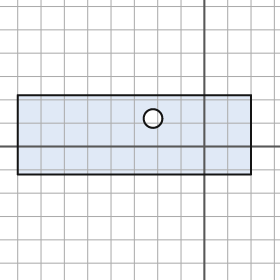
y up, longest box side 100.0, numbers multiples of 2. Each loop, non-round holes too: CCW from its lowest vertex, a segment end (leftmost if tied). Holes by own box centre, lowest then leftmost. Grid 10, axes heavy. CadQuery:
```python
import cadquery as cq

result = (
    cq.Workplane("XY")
    .moveTo(-80.0, -12.0)
    .lineTo(20.0, -12.0)
    .lineTo(20.0, 22.0)
    .lineTo(-80.0, 22.0)
    .close()
    .moveTo(-22.0, 12.0)
    .circle(4.0)
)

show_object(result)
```